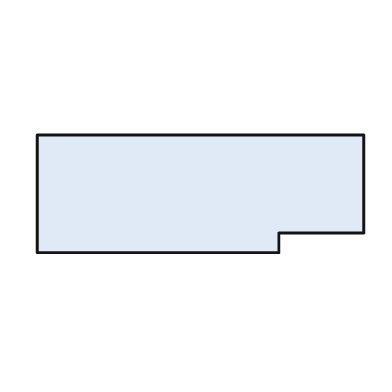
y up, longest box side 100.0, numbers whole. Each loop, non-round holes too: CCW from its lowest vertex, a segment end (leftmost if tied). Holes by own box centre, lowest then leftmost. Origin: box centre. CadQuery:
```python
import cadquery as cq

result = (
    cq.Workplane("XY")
    .moveTo(-50.0, -18.0)
    .lineTo(24.0, -18.0)
    .lineTo(24.0, -12.0)
    .lineTo(50.0, -12.0)
    .lineTo(50.0, 18.0)
    .lineTo(-50.0, 18.0)
    .close()
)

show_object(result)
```